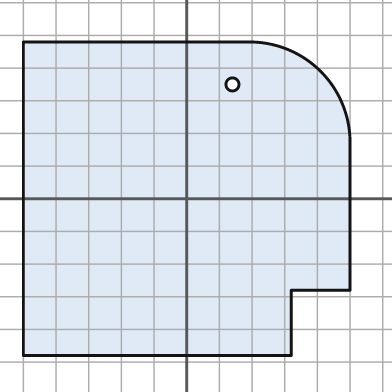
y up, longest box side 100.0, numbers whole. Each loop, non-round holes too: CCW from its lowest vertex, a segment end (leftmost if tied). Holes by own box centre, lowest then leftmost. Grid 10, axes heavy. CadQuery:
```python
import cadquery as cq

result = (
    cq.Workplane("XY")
    .moveTo(-50.0, -48.0)
    .lineTo(32.0, -48.0)
    .lineTo(32.0, -28.0)
    .lineTo(50.0, -28.0)
    .lineTo(50.0, 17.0)
    .threePointArc((41.0, 39.0), (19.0, 48.0))
    .lineTo(-50.0, 48.0)
    .close()
    .moveTo(14.0, 35.0)
    .circle(2.0)
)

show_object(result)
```